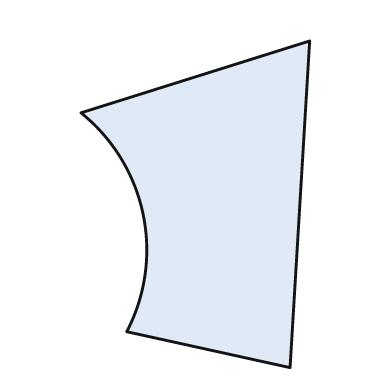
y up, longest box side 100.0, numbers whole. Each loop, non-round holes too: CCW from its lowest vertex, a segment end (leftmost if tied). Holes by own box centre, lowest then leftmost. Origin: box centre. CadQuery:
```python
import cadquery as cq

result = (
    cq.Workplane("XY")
    .moveTo(29.0, -50.0)
    .lineTo(35.0, 50.0)
    .lineTo(-35.0, 28.0)
    .threePointArc((-16.0, -3.0), (-21.0, -39.0))
    .close()
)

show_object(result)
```